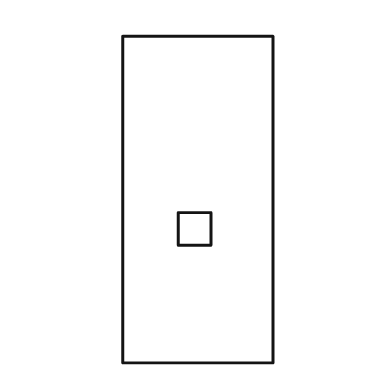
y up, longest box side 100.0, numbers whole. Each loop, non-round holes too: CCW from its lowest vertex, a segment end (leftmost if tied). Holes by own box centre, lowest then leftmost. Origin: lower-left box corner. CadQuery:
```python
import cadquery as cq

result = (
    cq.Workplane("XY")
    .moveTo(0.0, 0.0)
    .lineTo(46.0, 0.0)
    .lineTo(46.0, 100.0)
    .lineTo(0.0, 100.0)
    .close()
    .moveTo(17.0, 36.0)
    .lineTo(27.0, 36.0)
    .lineTo(27.0, 46.0)
    .lineTo(17.0, 46.0)
    .close()
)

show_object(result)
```